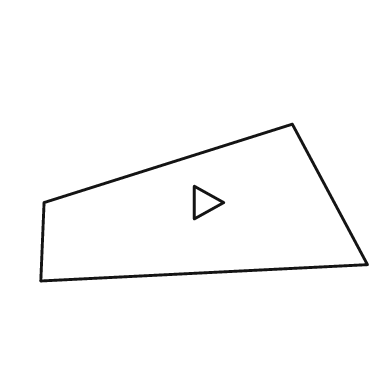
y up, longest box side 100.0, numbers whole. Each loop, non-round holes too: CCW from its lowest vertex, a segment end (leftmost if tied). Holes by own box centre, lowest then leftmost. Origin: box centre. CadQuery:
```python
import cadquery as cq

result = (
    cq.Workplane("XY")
    .moveTo(-50.0, -24.0)
    .lineTo(50.0, -19.0)
    .lineTo(27.0, 24.0)
    .lineTo(-49.0, 0.0)
    .close()
    .moveTo(-3.0, -5.0)
    .lineTo(6.0, 0.0)
    .lineTo(-3.0, 5.0)
    .close()
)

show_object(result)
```